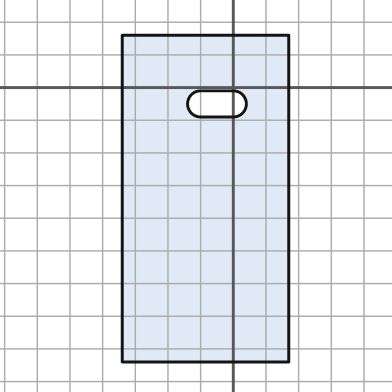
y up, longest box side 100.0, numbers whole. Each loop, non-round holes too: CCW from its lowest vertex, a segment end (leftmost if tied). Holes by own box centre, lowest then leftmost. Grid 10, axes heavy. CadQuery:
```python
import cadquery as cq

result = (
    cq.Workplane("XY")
    .moveTo(-34.0, -84.0)
    .lineTo(17.0, -84.0)
    .lineTo(17.0, 16.0)
    .lineTo(-34.0, 16.0)
    .close()
    .moveTo(-10.0, -9.0)
    .lineTo(0.0, -9.0)
    .threePointArc((4.0, -5.0), (0.0, -1.0))
    .lineTo(-10.0, -1.0)
    .threePointArc((-14.0, -5.0), (-10.0, -9.0))
    .close()
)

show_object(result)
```